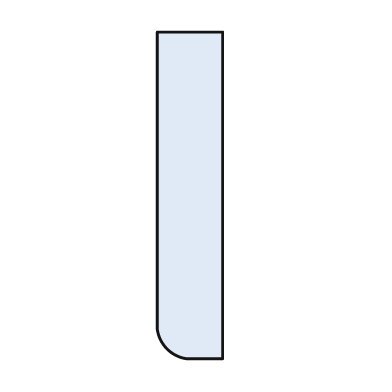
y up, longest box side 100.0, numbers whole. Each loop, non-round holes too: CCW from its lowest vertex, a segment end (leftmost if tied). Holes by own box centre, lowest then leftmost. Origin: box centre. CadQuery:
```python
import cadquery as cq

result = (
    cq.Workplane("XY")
    .moveTo(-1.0, -50.0)
    .lineTo(10.0, -50.0)
    .lineTo(10.0, 50.0)
    .lineTo(-10.0, 50.0)
    .lineTo(-10.0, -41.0)
    .threePointArc((-7.0, -47.0), (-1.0, -50.0))
    .close()
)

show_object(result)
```